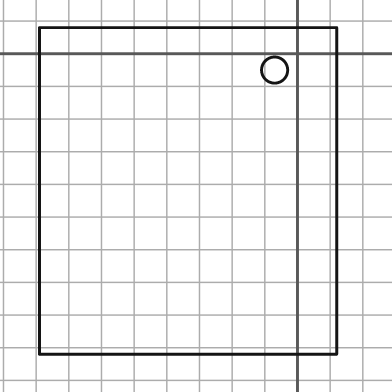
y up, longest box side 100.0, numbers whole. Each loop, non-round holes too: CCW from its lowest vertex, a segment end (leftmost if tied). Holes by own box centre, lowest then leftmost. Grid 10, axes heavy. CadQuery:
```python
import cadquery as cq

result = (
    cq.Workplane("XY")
    .moveTo(-79.0, -92.0)
    .lineTo(12.0, -92.0)
    .lineTo(12.0, 8.0)
    .lineTo(-79.0, 8.0)
    .close()
    .moveTo(-7.0, -5.0)
    .circle(4.0)
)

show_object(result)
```